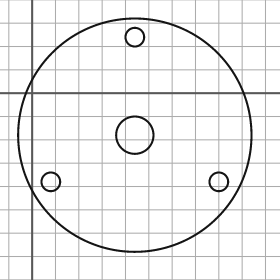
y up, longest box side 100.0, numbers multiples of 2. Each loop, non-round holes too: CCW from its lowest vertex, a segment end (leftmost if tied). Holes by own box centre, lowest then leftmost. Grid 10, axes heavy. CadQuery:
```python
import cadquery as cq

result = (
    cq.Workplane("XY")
    .moveTo(44.0, -18.0)
    .circle(50.0)
    .moveTo(8.0, -38.0)
    .circle(4.0)
    .moveTo(80.0, -38.0)
    .circle(4.0)
    .moveTo(44.0, -18.0)
    .circle(8.0)
    .moveTo(44.0, 24.0)
    .circle(4.0)
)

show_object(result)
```